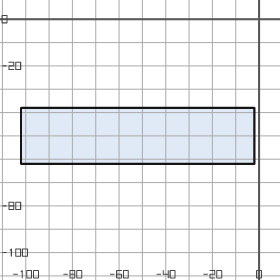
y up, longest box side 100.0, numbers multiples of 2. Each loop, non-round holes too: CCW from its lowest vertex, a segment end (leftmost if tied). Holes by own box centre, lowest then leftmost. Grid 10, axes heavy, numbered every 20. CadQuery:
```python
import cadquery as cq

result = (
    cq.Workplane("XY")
    .moveTo(-102.0, -62.0)
    .lineTo(-2.0, -62.0)
    .lineTo(-2.0, -38.0)
    .lineTo(-102.0, -38.0)
    .close()
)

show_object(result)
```